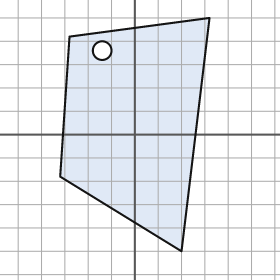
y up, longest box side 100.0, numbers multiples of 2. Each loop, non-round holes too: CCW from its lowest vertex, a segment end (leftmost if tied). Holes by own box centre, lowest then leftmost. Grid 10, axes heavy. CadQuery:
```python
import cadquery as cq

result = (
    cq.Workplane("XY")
    .moveTo(20.0, -50.0)
    .lineTo(32.0, 50.0)
    .lineTo(-28.0, 42.0)
    .lineTo(-32.0, -18.0)
    .close()
    .moveTo(-14.0, 36.0)
    .circle(4.0)
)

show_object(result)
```